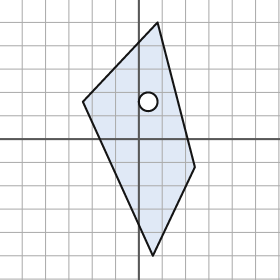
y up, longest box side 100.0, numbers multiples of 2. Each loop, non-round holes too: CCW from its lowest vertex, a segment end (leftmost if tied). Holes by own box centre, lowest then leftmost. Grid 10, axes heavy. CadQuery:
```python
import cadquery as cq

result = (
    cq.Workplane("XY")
    .moveTo(6.0, -50.0)
    .lineTo(24.0, -12.0)
    .lineTo(8.0, 50.0)
    .lineTo(-24.0, 16.0)
    .close()
    .moveTo(4.0, 16.0)
    .circle(4.0)
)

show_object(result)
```